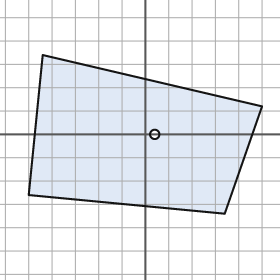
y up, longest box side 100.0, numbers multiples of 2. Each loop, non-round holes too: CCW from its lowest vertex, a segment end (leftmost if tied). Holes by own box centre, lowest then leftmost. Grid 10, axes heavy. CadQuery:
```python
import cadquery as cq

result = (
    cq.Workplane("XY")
    .moveTo(34.0, -34.0)
    .lineTo(50.0, 12.0)
    .lineTo(-44.0, 34.0)
    .lineTo(-50.0, -26.0)
    .close()
    .moveTo(4.0, 0.0)
    .circle(2.0)
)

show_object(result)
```